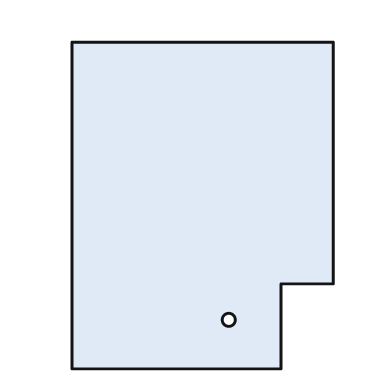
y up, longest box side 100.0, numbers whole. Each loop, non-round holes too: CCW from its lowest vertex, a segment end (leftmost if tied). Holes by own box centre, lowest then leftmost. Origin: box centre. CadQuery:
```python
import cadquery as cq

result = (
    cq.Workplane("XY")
    .moveTo(-40.0, -50.0)
    .lineTo(24.0, -50.0)
    .lineTo(24.0, -24.0)
    .lineTo(40.0, -24.0)
    .lineTo(40.0, 50.0)
    .lineTo(-40.0, 50.0)
    .close()
    .moveTo(8.0, -35.0)
    .circle(2.0)
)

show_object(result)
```